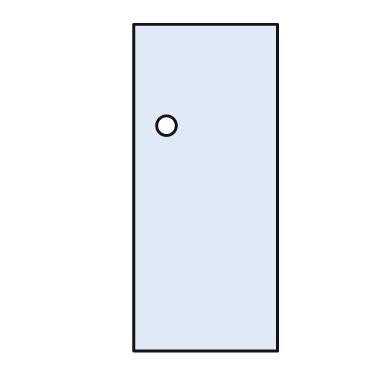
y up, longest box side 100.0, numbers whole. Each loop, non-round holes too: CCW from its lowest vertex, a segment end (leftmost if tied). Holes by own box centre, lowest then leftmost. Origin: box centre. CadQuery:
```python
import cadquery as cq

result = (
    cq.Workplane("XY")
    .moveTo(-22.0, -50.0)
    .lineTo(22.0, -50.0)
    .lineTo(22.0, 50.0)
    .lineTo(-22.0, 50.0)
    .close()
    .moveTo(-12.0, 19.0)
    .circle(3.0)
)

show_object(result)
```